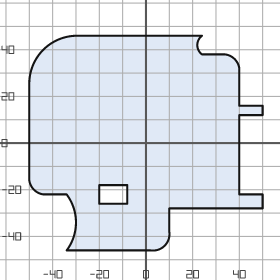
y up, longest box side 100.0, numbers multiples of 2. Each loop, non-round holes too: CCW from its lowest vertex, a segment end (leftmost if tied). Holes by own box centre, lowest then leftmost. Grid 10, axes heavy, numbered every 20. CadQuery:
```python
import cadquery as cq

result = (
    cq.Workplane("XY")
    .moveTo(-34.0, -46.0)
    .lineTo(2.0, -46.0)
    .threePointArc((8.0, -44.0), (10.0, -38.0))
    .lineTo(10.0, -28.0)
    .lineTo(50.0, -28.0)
    .lineTo(50.0, -22.0)
    .lineTo(40.0, -22.0)
    .lineTo(40.0, 12.0)
    .lineTo(50.0, 12.0)
    .lineTo(50.0, 16.0)
    .lineTo(40.0, 16.0)
    .lineTo(40.0, 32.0)
    .threePointArc((38.0, 36.0), (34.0, 38.0))
    .lineTo(24.0, 38.0)
    .threePointArc((22.0, 42.0), (24.0, 46.0))
    .lineTo(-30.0, 46.0)
    .threePointArc((-44.0, 40.0), (-50.0, 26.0))
    .lineTo(-50.0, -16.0)
    .threePointArc((-48.0, -20.0), (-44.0, -22.0))
    .lineTo(-34.0, -22.0)
    .threePointArc((-30.0, -34.0), (-34.0, -46.0))
    .close()
    .moveTo(-20.0, -26.0)
    .lineTo(-8.0, -26.0)
    .lineTo(-8.0, -18.0)
    .lineTo(-20.0, -18.0)
    .close()
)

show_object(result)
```